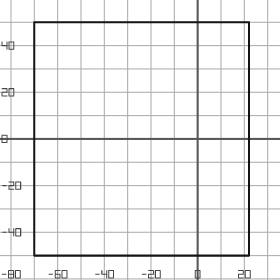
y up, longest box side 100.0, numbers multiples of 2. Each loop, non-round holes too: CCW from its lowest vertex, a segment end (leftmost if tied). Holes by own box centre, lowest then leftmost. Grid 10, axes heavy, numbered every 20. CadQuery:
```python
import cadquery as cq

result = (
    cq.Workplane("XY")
    .moveTo(-70.0, -50.0)
    .lineTo(22.0, -50.0)
    .lineTo(22.0, 50.0)
    .lineTo(-70.0, 50.0)
    .close()
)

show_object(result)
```